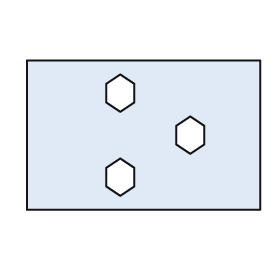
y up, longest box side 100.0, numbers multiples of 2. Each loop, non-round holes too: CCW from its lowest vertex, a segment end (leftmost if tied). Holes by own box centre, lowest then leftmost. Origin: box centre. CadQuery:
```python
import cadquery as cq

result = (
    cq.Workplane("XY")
    .moveTo(-50.0, -32.0)
    .lineTo(50.0, -32.0)
    .lineTo(50.0, 32.0)
    .lineTo(-50.0, 32.0)
    .close()
    .moveTo(-10.0, -26.0)
    .lineTo(-4.0, -22.0)
    .lineTo(-4.0, -14.0)
    .lineTo(-10.0, -10.0)
    .lineTo(-16.0, -14.0)
    .lineTo(-16.0, -22.0)
    .close()
    .moveTo(20.0, -8.0)
    .lineTo(26.0, -4.0)
    .lineTo(26.0, 4.0)
    .lineTo(20.0, 8.0)
    .lineTo(14.0, 4.0)
    .lineTo(14.0, -4.0)
    .close()
    .moveTo(-10.0, 10.0)
    .lineTo(-4.0, 14.0)
    .lineTo(-4.0, 22.0)
    .lineTo(-10.0, 26.0)
    .lineTo(-16.0, 22.0)
    .lineTo(-16.0, 14.0)
    .close()
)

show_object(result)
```